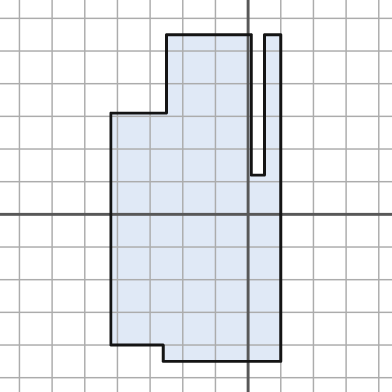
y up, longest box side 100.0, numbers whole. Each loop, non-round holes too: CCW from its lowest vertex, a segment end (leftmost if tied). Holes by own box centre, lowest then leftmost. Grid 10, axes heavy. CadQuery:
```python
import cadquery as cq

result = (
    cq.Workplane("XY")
    .moveTo(-26.0, -45.0)
    .lineTo(10.0, -45.0)
    .lineTo(10.0, 55.0)
    .lineTo(5.0, 55.0)
    .lineTo(5.0, 12.0)
    .lineTo(1.0, 12.0)
    .lineTo(1.0, 55.0)
    .lineTo(-25.0, 55.0)
    .lineTo(-25.0, 31.0)
    .lineTo(-42.0, 31.0)
    .lineTo(-42.0, -40.0)
    .lineTo(-26.0, -40.0)
    .close()
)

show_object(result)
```